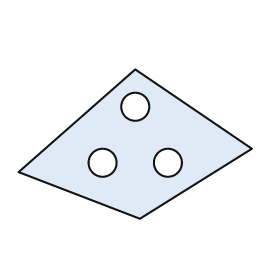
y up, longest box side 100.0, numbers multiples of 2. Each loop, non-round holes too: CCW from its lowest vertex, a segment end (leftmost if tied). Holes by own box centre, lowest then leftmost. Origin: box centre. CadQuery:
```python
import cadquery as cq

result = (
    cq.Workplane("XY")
    .moveTo(2.0, -32.0)
    .lineTo(50.0, -2.0)
    .lineTo(0.0, 32.0)
    .lineTo(-50.0, -12.0)
    .close()
    .moveTo(-14.0, -8.0)
    .circle(6.0)
    .moveTo(14.0, -8.0)
    .circle(6.0)
    .moveTo(0.0, 16.0)
    .circle(6.0)
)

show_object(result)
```